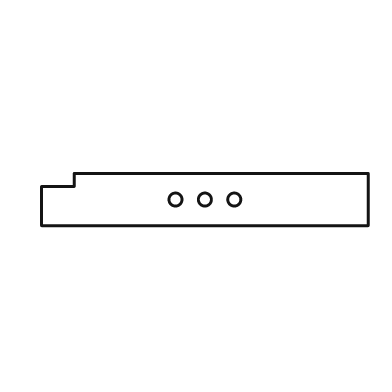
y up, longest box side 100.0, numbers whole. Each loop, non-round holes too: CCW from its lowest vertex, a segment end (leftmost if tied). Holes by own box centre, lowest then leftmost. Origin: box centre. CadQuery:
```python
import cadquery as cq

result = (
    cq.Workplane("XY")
    .moveTo(-50.0, -8.0)
    .lineTo(50.0, -8.0)
    .lineTo(50.0, 8.0)
    .lineTo(-40.0, 8.0)
    .lineTo(-40.0, 4.0)
    .lineTo(-50.0, 4.0)
    .close()
    .moveTo(-9.0, 0.0)
    .circle(2.0)
    .moveTo(0.0, 0.0)
    .circle(2.0)
    .moveTo(9.0, 0.0)
    .circle(2.0)
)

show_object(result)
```